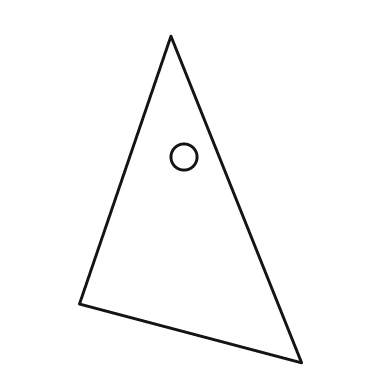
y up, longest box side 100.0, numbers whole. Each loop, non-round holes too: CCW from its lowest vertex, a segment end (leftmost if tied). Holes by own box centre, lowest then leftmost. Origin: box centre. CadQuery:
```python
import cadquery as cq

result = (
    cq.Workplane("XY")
    .moveTo(34.0, -50.0)
    .lineTo(-6.0, 50.0)
    .lineTo(-34.0, -32.0)
    .close()
    .moveTo(-2.0, 13.0)
    .circle(4.0)
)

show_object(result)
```